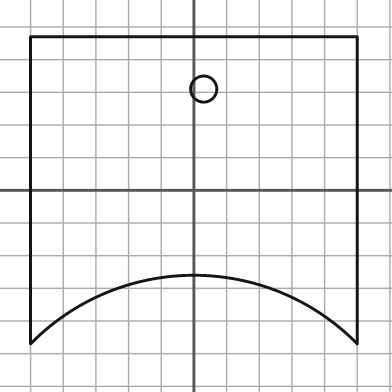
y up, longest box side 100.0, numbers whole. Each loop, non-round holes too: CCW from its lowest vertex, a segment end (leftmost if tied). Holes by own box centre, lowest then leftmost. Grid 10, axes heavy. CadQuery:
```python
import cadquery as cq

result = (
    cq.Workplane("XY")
    .moveTo(-50.0, -47.0)
    .threePointArc((0.0, -26.0), (50.0, -47.0))
    .lineTo(50.0, 47.0)
    .lineTo(-50.0, 47.0)
    .close()
    .moveTo(3.0, 31.0)
    .circle(4.0)
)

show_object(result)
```